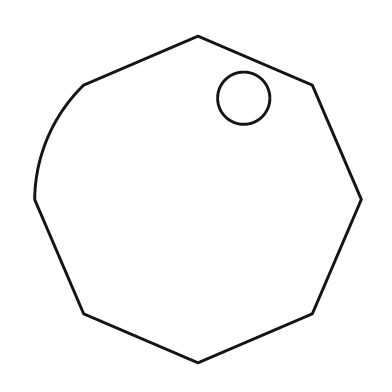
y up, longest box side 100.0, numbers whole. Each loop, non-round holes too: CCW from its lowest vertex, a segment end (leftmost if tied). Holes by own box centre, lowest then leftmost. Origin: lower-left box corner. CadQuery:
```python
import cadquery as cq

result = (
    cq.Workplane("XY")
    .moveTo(50.0, 0.0)
    .lineTo(85.0, 15.0)
    .lineTo(100.0, 50.0)
    .lineTo(85.0, 85.0)
    .lineTo(50.0, 100.0)
    .lineTo(15.0, 85.0)
    .threePointArc((4.0, 69.0), (0.0, 50.0))
    .lineTo(15.0, 15.0)
    .close()
    .moveTo(64.0, 81.0)
    .circle(8.0)
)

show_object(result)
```